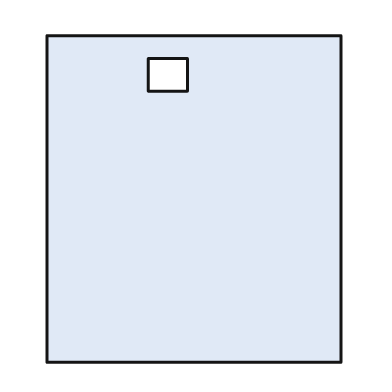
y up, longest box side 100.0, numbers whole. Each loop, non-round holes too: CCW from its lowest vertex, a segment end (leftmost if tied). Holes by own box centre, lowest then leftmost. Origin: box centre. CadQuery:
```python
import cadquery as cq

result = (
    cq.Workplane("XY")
    .moveTo(-45.0, -50.0)
    .lineTo(45.0, -50.0)
    .lineTo(45.0, 50.0)
    .lineTo(-45.0, 50.0)
    .close()
    .moveTo(-14.0, 33.0)
    .lineTo(-2.0, 33.0)
    .lineTo(-2.0, 43.0)
    .lineTo(-14.0, 43.0)
    .close()
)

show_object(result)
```